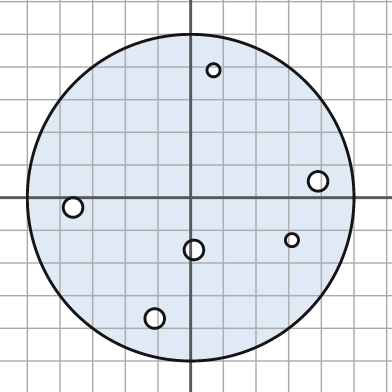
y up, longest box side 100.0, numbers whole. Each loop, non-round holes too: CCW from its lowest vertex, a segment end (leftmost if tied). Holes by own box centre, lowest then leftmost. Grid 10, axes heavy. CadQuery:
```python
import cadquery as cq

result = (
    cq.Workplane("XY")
    .moveTo(0.0, 0.0)
    .circle(50.0)
    .moveTo(-11.0, -37.0)
    .circle(3.0)
    .moveTo(1.0, -16.0)
    .circle(3.0)
    .moveTo(31.0, -13.0)
    .circle(2.0)
    .moveTo(-36.0, -3.0)
    .circle(3.0)
    .moveTo(39.0, 5.0)
    .circle(3.0)
    .moveTo(7.0, 39.0)
    .circle(2.0)
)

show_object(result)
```